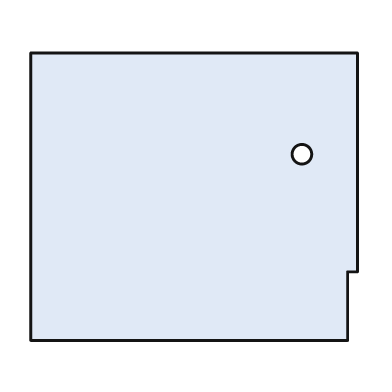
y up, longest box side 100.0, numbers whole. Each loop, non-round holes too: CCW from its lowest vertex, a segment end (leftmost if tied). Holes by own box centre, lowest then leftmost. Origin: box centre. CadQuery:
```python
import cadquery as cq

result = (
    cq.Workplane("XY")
    .moveTo(-50.0, -44.0)
    .lineTo(47.0, -44.0)
    .lineTo(47.0, -23.0)
    .lineTo(50.0, -23.0)
    .lineTo(50.0, 44.0)
    .lineTo(-50.0, 44.0)
    .close()
    .moveTo(33.0, 13.0)
    .circle(3.0)
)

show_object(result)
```